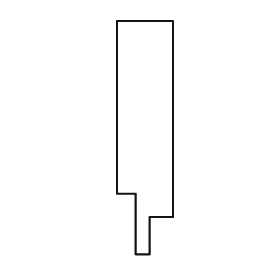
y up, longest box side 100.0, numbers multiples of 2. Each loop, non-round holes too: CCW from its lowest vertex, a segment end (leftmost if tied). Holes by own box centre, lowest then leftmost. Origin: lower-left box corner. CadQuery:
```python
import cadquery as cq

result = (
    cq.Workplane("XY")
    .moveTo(8.0, 0.0)
    .lineTo(14.0, 0.0)
    .lineTo(14.0, 16.0)
    .lineTo(24.0, 16.0)
    .lineTo(24.0, 100.0)
    .lineTo(0.0, 100.0)
    .lineTo(0.0, 26.0)
    .lineTo(8.0, 26.0)
    .close()
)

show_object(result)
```